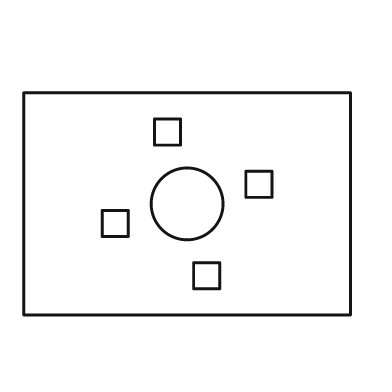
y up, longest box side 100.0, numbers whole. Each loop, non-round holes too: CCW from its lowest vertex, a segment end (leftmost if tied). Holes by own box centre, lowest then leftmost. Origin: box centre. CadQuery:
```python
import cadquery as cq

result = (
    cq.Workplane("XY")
    .moveTo(-50.0, -34.0)
    .lineTo(50.0, -34.0)
    .lineTo(50.0, 34.0)
    .lineTo(-50.0, 34.0)
    .close()
    .moveTo(2.0, -26.0)
    .lineTo(10.0, -26.0)
    .lineTo(10.0, -18.0)
    .lineTo(2.0, -18.0)
    .close()
    .moveTo(-26.0, -10.0)
    .lineTo(-18.0, -10.0)
    .lineTo(-18.0, -2.0)
    .lineTo(-26.0, -2.0)
    .close()
    .moveTo(0.0, 0.0)
    .circle(11.0)
    .moveTo(18.0, 2.0)
    .lineTo(26.0, 2.0)
    .lineTo(26.0, 10.0)
    .lineTo(18.0, 10.0)
    .close()
    .moveTo(-10.0, 18.0)
    .lineTo(-2.0, 18.0)
    .lineTo(-2.0, 26.0)
    .lineTo(-10.0, 26.0)
    .close()
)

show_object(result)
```